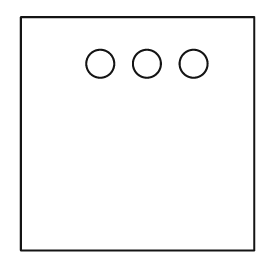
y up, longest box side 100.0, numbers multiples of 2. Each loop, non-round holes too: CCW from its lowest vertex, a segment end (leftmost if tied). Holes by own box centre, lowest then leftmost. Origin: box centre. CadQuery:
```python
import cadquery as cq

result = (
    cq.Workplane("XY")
    .moveTo(-50.0, -50.0)
    .lineTo(50.0, -50.0)
    .lineTo(50.0, 50.0)
    .lineTo(-50.0, 50.0)
    .close()
    .moveTo(-16.0, 30.0)
    .circle(6.0)
    .moveTo(4.0, 30.0)
    .circle(6.0)
    .moveTo(24.0, 30.0)
    .circle(6.0)
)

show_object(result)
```